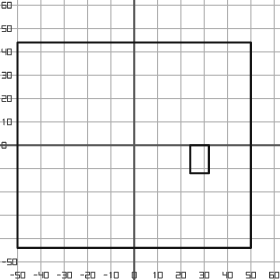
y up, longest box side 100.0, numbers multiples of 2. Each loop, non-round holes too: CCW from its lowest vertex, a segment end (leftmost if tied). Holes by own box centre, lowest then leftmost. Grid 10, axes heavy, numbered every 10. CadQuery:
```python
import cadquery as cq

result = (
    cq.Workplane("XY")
    .moveTo(-50.0, -44.0)
    .lineTo(50.0, -44.0)
    .lineTo(50.0, 44.0)
    .lineTo(-50.0, 44.0)
    .close()
    .moveTo(24.0, -12.0)
    .lineTo(32.0, -12.0)
    .lineTo(32.0, 0.0)
    .lineTo(24.0, 0.0)
    .close()
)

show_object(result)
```